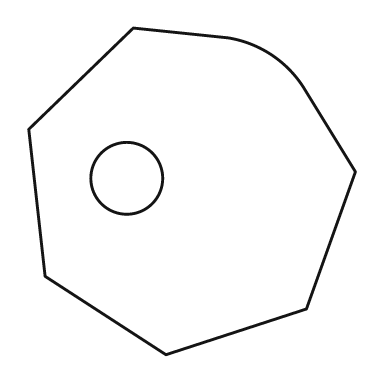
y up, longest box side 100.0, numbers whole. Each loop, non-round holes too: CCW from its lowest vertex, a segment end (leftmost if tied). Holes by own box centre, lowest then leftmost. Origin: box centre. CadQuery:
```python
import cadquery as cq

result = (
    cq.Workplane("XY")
    .moveTo(-8.0, -50.0)
    .lineTo(35.0, -36.0)
    .lineTo(50.0, 6.0)
    .lineTo(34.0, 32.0)
    .threePointArc((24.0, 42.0), (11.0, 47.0))
    .lineTo(-18.0, 50.0)
    .lineTo(-50.0, 19.0)
    .lineTo(-45.0, -26.0)
    .close()
    .moveTo(-20.0, 4.0)
    .circle(11.0)
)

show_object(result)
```